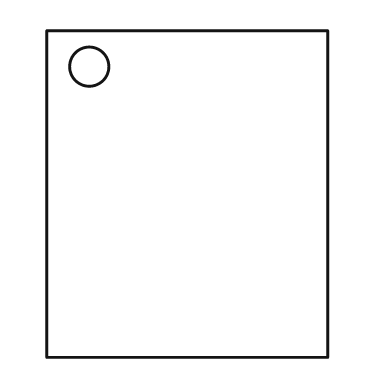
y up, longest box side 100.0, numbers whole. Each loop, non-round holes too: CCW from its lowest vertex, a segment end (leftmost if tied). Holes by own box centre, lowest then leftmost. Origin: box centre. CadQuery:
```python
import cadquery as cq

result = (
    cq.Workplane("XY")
    .moveTo(-43.0, -50.0)
    .lineTo(43.0, -50.0)
    .lineTo(43.0, 50.0)
    .lineTo(-43.0, 50.0)
    .close()
    .moveTo(-30.0, 39.0)
    .circle(6.0)
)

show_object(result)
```